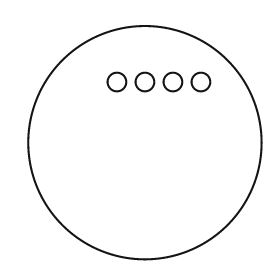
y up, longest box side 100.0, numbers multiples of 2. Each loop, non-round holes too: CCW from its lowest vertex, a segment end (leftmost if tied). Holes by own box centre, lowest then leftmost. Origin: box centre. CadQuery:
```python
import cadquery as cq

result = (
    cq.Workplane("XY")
    .moveTo(0.0, 0.0)
    .circle(50.0)
    .moveTo(-12.0, 26.0)
    .circle(4.0)
    .moveTo(0.0, 26.0)
    .circle(4.0)
    .moveTo(12.0, 26.0)
    .circle(4.0)
    .moveTo(24.0, 26.0)
    .circle(4.0)
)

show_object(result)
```